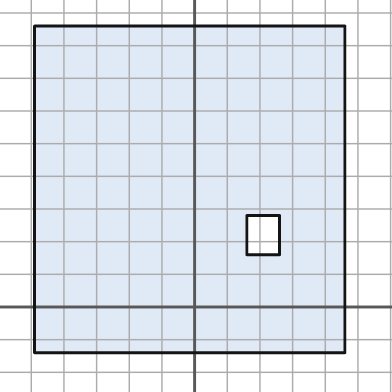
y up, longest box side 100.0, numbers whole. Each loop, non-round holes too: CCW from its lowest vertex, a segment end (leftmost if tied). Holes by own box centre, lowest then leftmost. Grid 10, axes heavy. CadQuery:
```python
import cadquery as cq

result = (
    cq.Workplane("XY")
    .moveTo(-49.0, -14.0)
    .lineTo(46.0, -14.0)
    .lineTo(46.0, 86.0)
    .lineTo(-49.0, 86.0)
    .close()
    .moveTo(16.0, 16.0)
    .lineTo(26.0, 16.0)
    .lineTo(26.0, 28.0)
    .lineTo(16.0, 28.0)
    .close()
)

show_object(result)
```